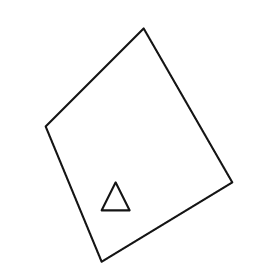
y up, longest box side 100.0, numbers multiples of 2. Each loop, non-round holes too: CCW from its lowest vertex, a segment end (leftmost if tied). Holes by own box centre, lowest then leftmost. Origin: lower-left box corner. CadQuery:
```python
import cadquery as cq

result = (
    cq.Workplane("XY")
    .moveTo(24.0, 0.0)
    .lineTo(80.0, 34.0)
    .lineTo(42.0, 100.0)
    .lineTo(0.0, 58.0)
    .close()
    .moveTo(24.0, 22.0)
    .lineTo(36.0, 22.0)
    .lineTo(30.0, 34.0)
    .close()
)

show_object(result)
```